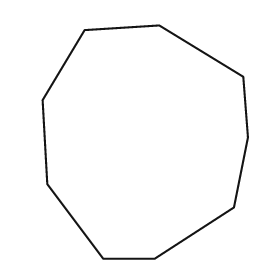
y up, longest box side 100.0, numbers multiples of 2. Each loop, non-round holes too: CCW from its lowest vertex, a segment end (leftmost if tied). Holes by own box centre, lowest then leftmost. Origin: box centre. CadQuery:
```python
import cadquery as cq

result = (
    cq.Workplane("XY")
    .moveTo(-18.0, -50.0)
    .lineTo(4.0, -50.0)
    .lineTo(38.0, -28.0)
    .lineTo(44.0, 2.0)
    .lineTo(42.0, 28.0)
    .lineTo(6.0, 50.0)
    .lineTo(-26.0, 48.0)
    .lineTo(-44.0, 18.0)
    .lineTo(-42.0, -18.0)
    .close()
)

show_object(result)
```